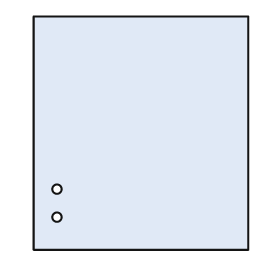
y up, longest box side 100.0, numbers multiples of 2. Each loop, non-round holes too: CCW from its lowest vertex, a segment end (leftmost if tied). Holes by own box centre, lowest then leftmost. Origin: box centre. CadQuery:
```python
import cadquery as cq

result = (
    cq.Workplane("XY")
    .moveTo(-46.0, -50.0)
    .lineTo(46.0, -50.0)
    .lineTo(46.0, 50.0)
    .lineTo(-46.0, 50.0)
    .close()
    .moveTo(-36.0, -36.0)
    .circle(2.0)
    .moveTo(-36.0, -24.0)
    .circle(2.0)
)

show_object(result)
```